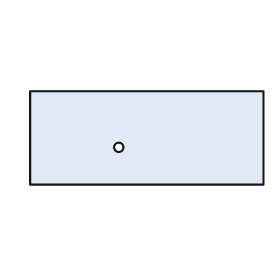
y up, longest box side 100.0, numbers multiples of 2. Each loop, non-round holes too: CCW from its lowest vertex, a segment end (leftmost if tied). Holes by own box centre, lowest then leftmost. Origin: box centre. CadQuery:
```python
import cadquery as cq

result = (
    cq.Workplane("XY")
    .moveTo(-50.0, -20.0)
    .lineTo(50.0, -20.0)
    .lineTo(50.0, 20.0)
    .lineTo(-50.0, 20.0)
    .close()
    .moveTo(-12.0, -4.0)
    .circle(2.0)
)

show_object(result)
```